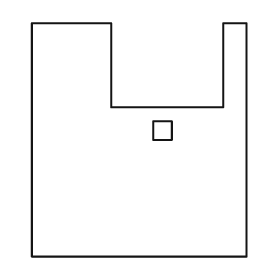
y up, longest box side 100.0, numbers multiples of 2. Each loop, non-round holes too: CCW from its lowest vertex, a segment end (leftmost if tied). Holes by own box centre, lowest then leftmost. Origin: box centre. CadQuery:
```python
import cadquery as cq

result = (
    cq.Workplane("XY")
    .moveTo(-46.0, -50.0)
    .lineTo(46.0, -50.0)
    .lineTo(46.0, 50.0)
    .lineTo(36.0, 50.0)
    .lineTo(36.0, 14.0)
    .lineTo(-12.0, 14.0)
    .lineTo(-12.0, 50.0)
    .lineTo(-46.0, 50.0)
    .close()
    .moveTo(6.0, 0.0)
    .lineTo(14.0, 0.0)
    .lineTo(14.0, 8.0)
    .lineTo(6.0, 8.0)
    .close()
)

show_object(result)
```